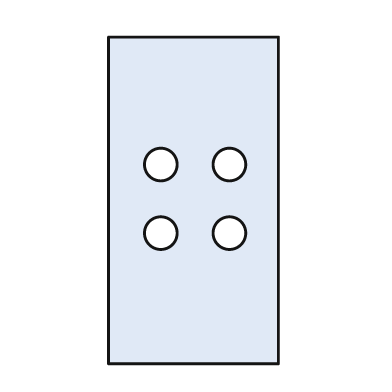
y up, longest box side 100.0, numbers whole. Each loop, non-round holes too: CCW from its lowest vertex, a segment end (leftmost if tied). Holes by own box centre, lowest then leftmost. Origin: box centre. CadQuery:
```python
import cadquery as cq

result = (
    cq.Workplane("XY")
    .moveTo(-26.0, -50.0)
    .lineTo(26.0, -50.0)
    .lineTo(26.0, 50.0)
    .lineTo(-26.0, 50.0)
    .close()
    .moveTo(-10.0, -10.0)
    .circle(5.0)
    .moveTo(11.0, -10.0)
    .circle(5.0)
    .moveTo(-10.0, 11.0)
    .circle(5.0)
    .moveTo(11.0, 11.0)
    .circle(5.0)
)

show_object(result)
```